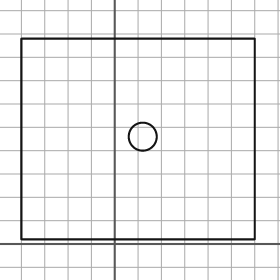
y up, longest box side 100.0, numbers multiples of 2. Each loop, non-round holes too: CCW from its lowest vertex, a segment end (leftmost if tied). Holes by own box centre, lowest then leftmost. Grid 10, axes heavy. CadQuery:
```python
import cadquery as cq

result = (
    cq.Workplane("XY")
    .moveTo(-40.0, 2.0)
    .lineTo(60.0, 2.0)
    .lineTo(60.0, 88.0)
    .lineTo(-40.0, 88.0)
    .close()
    .moveTo(12.0, 46.0)
    .circle(6.0)
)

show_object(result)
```